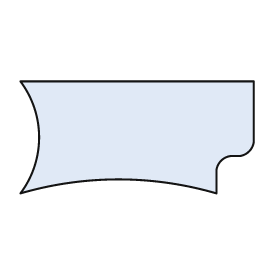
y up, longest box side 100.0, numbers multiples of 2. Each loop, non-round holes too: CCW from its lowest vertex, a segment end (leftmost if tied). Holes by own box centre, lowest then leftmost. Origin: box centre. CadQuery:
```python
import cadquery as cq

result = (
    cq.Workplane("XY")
    .moveTo(-50.0, -24.0)
    .threePointArc((-8.0, -18.0), (34.0, -24.0))
    .lineTo(34.0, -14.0)
    .threePointArc((36.0, -10.0), (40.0, -8.0))
    .lineTo(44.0, -8.0)
    .threePointArc((48.0, -6.0), (50.0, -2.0))
    .lineTo(50.0, 24.0)
    .lineTo(-50.0, 24.0)
    .threePointArc((-42.0, 0.0), (-50.0, -24.0))
    .close()
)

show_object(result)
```